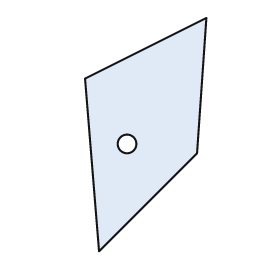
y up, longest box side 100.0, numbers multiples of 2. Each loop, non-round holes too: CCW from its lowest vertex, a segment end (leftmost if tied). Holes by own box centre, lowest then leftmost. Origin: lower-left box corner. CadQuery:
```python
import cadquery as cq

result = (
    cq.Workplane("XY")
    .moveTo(6.0, 0.0)
    .lineTo(48.0, 42.0)
    .lineTo(52.0, 100.0)
    .lineTo(0.0, 74.0)
    .close()
    .moveTo(18.0, 46.0)
    .circle(4.0)
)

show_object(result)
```